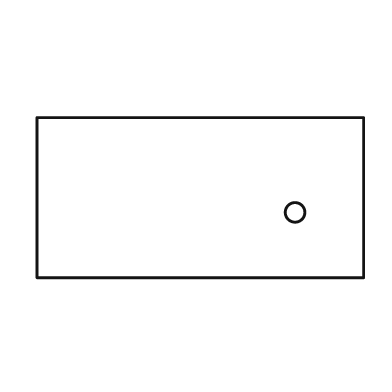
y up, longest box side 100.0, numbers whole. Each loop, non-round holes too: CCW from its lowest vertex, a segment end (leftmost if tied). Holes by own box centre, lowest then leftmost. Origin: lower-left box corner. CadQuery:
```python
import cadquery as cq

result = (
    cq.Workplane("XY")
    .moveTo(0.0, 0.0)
    .lineTo(100.0, 0.0)
    .lineTo(100.0, 49.0)
    .lineTo(0.0, 49.0)
    .close()
    .moveTo(79.0, 20.0)
    .circle(3.0)
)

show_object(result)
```